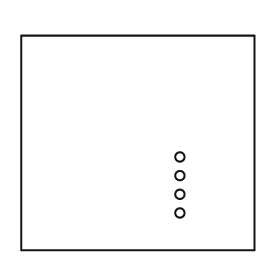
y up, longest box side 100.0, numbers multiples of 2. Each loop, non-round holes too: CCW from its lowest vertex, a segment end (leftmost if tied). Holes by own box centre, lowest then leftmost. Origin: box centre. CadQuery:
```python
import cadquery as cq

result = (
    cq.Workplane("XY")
    .moveTo(-50.0, -46.0)
    .lineTo(50.0, -46.0)
    .lineTo(50.0, 46.0)
    .lineTo(-50.0, 46.0)
    .close()
    .moveTo(18.0, -30.0)
    .circle(2.0)
    .moveTo(18.0, -22.0)
    .circle(2.0)
    .moveTo(18.0, -14.0)
    .circle(2.0)
    .moveTo(18.0, -6.0)
    .circle(2.0)
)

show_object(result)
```